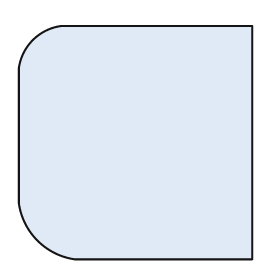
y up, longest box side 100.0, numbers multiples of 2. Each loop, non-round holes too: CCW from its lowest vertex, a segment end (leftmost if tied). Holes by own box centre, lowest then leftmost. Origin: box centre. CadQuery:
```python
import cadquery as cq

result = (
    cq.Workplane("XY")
    .moveTo(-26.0, -50.0)
    .lineTo(50.0, -50.0)
    .lineTo(50.0, 50.0)
    .lineTo(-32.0, 50.0)
    .threePointArc((-44.0, 44.0), (-50.0, 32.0))
    .lineTo(-50.0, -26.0)
    .threePointArc((-42.0, -42.0), (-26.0, -50.0))
    .close()
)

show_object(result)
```